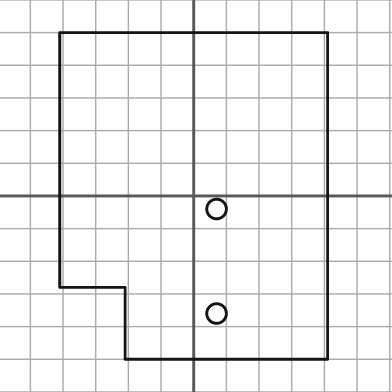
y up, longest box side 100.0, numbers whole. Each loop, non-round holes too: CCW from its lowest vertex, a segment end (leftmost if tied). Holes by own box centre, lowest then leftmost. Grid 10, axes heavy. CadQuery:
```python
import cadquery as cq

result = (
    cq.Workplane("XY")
    .moveTo(-21.0, -50.0)
    .lineTo(41.0, -50.0)
    .lineTo(41.0, 50.0)
    .lineTo(-41.0, 50.0)
    .lineTo(-41.0, -28.0)
    .lineTo(-21.0, -28.0)
    .close()
    .moveTo(7.0, -36.0)
    .circle(3.0)
    .moveTo(7.0, -4.0)
    .circle(3.0)
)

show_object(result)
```